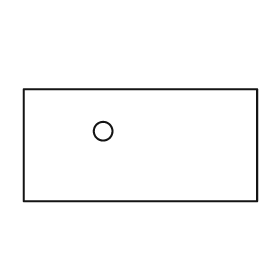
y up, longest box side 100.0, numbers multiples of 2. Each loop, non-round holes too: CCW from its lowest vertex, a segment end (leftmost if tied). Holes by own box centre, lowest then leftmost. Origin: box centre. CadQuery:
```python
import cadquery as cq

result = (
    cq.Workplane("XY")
    .moveTo(-50.0, -24.0)
    .lineTo(50.0, -24.0)
    .lineTo(50.0, 24.0)
    .lineTo(-50.0, 24.0)
    .close()
    .moveTo(-16.0, 6.0)
    .circle(4.0)
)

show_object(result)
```